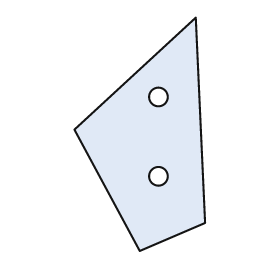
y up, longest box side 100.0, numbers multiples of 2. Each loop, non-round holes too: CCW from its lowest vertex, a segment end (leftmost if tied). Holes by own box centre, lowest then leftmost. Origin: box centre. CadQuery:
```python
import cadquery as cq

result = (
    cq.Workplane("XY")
    .moveTo(0.0, -50.0)
    .lineTo(28.0, -38.0)
    .lineTo(24.0, 50.0)
    .lineTo(-28.0, 2.0)
    .close()
    .moveTo(8.0, -18.0)
    .circle(4.0)
    .moveTo(8.0, 16.0)
    .circle(4.0)
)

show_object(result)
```